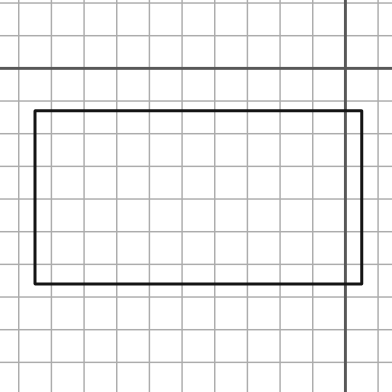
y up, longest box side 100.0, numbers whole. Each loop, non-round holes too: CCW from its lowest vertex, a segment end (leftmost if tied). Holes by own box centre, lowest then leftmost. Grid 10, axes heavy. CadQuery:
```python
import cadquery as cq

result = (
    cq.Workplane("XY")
    .moveTo(-95.0, -66.0)
    .lineTo(5.0, -66.0)
    .lineTo(5.0, -13.0)
    .lineTo(-95.0, -13.0)
    .close()
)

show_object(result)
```